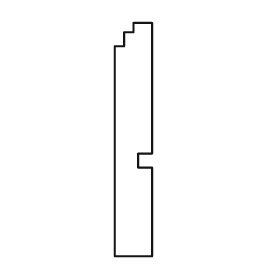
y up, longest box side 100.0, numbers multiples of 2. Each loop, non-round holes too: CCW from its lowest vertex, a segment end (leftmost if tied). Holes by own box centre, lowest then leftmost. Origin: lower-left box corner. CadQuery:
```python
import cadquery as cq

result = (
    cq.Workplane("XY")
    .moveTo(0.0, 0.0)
    .lineTo(16.0, 0.0)
    .lineTo(16.0, 38.0)
    .lineTo(10.0, 38.0)
    .lineTo(10.0, 44.0)
    .lineTo(16.0, 44.0)
    .lineTo(16.0, 100.0)
    .lineTo(8.0, 100.0)
    .lineTo(8.0, 96.0)
    .lineTo(4.0, 96.0)
    .lineTo(4.0, 90.0)
    .lineTo(0.0, 90.0)
    .close()
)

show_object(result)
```